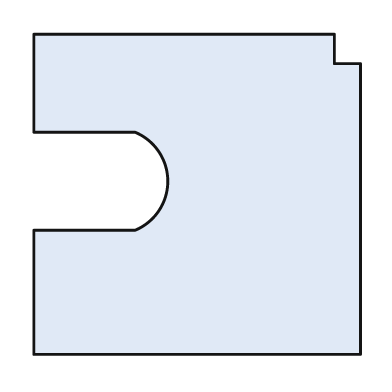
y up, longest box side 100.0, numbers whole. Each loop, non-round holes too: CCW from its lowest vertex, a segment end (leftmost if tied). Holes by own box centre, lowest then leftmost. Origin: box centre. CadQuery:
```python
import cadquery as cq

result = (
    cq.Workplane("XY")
    .moveTo(-50.0, -49.0)
    .lineTo(50.0, -49.0)
    .lineTo(50.0, 40.0)
    .lineTo(42.0, 40.0)
    .lineTo(42.0, 49.0)
    .lineTo(-50.0, 49.0)
    .lineTo(-50.0, 19.0)
    .lineTo(-19.0, 19.0)
    .threePointArc((-9.0, 4.0), (-19.0, -11.0))
    .lineTo(-50.0, -11.0)
    .close()
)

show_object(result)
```